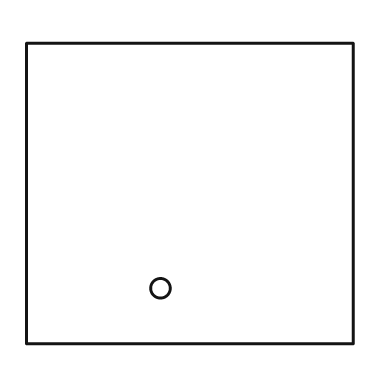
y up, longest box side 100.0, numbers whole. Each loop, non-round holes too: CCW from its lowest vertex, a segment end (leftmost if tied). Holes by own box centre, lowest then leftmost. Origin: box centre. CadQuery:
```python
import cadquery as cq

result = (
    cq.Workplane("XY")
    .moveTo(-50.0, -46.0)
    .lineTo(50.0, -46.0)
    .lineTo(50.0, 46.0)
    .lineTo(-50.0, 46.0)
    .close()
    .moveTo(-9.0, -29.0)
    .circle(3.0)
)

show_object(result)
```